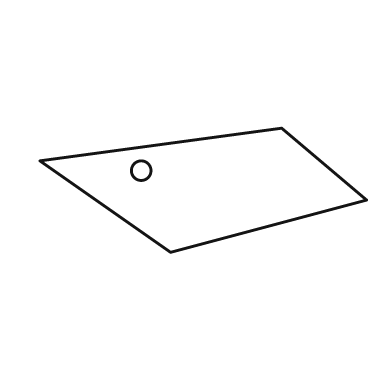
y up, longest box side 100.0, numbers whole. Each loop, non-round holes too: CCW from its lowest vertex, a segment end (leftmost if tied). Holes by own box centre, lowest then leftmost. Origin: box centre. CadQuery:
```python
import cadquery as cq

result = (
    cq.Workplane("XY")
    .moveTo(-10.0, -19.0)
    .lineTo(50.0, -3.0)
    .lineTo(24.0, 19.0)
    .lineTo(-50.0, 9.0)
    .close()
    .moveTo(-19.0, 6.0)
    .circle(3.0)
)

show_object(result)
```